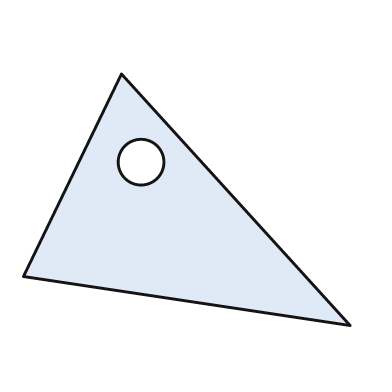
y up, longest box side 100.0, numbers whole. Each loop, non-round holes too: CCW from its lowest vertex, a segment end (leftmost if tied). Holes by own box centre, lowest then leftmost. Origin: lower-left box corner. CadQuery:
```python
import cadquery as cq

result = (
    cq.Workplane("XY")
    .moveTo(100.0, 0.0)
    .lineTo(30.0, 77.0)
    .lineTo(0.0, 15.0)
    .close()
    .moveTo(36.0, 50.0)
    .circle(7.0)
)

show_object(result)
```